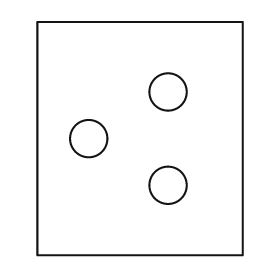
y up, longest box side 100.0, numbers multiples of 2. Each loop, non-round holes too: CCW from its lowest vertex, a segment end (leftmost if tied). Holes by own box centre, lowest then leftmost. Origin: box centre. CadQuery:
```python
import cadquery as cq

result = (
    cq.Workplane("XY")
    .moveTo(-44.0, -50.0)
    .lineTo(44.0, -50.0)
    .lineTo(44.0, 50.0)
    .lineTo(-44.0, 50.0)
    .close()
    .moveTo(12.0, -20.0)
    .circle(8.0)
    .moveTo(-22.0, 0.0)
    .circle(8.0)
    .moveTo(12.0, 20.0)
    .circle(8.0)
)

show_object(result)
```